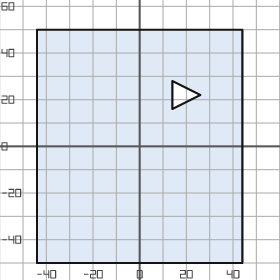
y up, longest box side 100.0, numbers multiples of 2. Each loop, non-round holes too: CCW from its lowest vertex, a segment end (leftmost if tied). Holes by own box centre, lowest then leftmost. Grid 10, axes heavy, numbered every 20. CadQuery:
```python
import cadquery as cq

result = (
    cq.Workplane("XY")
    .moveTo(-44.0, -50.0)
    .lineTo(44.0, -50.0)
    .lineTo(44.0, 50.0)
    .lineTo(-44.0, 50.0)
    .close()
    .moveTo(14.0, 16.0)
    .lineTo(26.0, 22.0)
    .lineTo(14.0, 28.0)
    .close()
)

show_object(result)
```